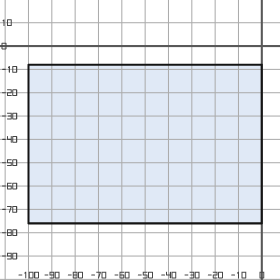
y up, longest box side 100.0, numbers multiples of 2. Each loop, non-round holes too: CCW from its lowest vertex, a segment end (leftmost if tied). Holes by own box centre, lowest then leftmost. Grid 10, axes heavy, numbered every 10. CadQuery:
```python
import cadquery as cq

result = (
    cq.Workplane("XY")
    .moveTo(-100.0, -76.0)
    .lineTo(0.0, -76.0)
    .lineTo(0.0, -8.0)
    .lineTo(-100.0, -8.0)
    .close()
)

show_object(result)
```